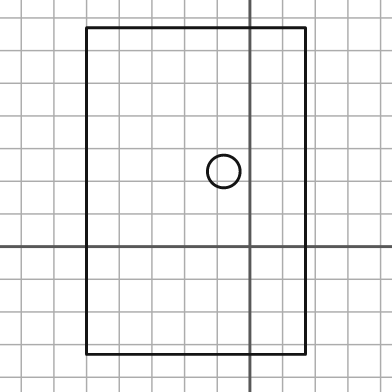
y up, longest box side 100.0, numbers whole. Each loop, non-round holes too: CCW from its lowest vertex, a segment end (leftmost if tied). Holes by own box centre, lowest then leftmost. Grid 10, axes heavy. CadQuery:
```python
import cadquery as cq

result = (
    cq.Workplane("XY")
    .moveTo(-50.0, -33.0)
    .lineTo(17.0, -33.0)
    .lineTo(17.0, 67.0)
    .lineTo(-50.0, 67.0)
    .close()
    .moveTo(-8.0, 23.0)
    .circle(5.0)
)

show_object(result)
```